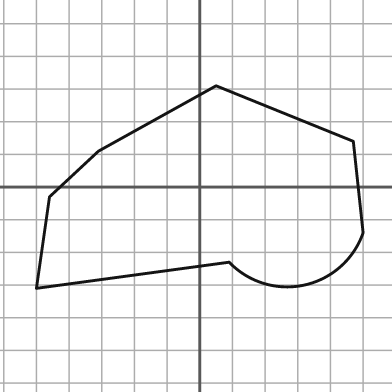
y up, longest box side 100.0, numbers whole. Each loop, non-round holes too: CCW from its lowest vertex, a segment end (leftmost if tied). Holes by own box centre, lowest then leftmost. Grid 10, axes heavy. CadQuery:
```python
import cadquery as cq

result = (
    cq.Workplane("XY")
    .moveTo(-50.0, -31.0)
    .lineTo(9.0, -23.0)
    .threePointArc((32.0, -30.0), (50.0, -14.0))
    .lineTo(47.0, 14.0)
    .lineTo(5.0, 31.0)
    .lineTo(-31.0, 11.0)
    .lineTo(-46.0, -3.0)
    .close()
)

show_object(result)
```